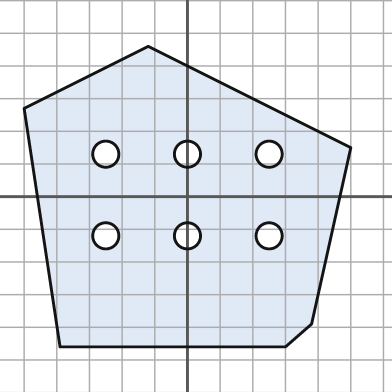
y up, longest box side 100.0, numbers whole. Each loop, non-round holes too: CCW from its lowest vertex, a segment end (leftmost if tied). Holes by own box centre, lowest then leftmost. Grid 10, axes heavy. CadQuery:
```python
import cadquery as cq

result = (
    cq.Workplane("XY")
    .moveTo(-39.0, -46.0)
    .lineTo(30.0, -46.0)
    .lineTo(38.0, -39.0)
    .lineTo(50.0, 15.0)
    .lineTo(-12.0, 46.0)
    .lineTo(-50.0, 27.0)
    .close()
    .moveTo(-25.0, -12.0)
    .circle(4.0)
    .moveTo(0.0, -12.0)
    .circle(4.0)
    .moveTo(25.0, -12.0)
    .circle(4.0)
    .moveTo(-25.0, 13.0)
    .circle(4.0)
    .moveTo(0.0, 13.0)
    .circle(4.0)
    .moveTo(25.0, 13.0)
    .circle(4.0)
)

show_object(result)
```